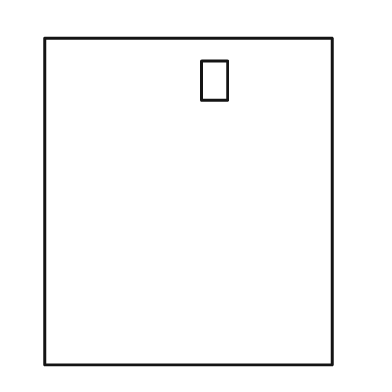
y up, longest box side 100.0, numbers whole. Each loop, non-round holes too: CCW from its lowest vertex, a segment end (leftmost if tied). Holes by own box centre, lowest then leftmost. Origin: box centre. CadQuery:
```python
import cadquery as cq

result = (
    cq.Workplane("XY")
    .moveTo(-44.0, -50.0)
    .lineTo(44.0, -50.0)
    .lineTo(44.0, 50.0)
    .lineTo(-44.0, 50.0)
    .close()
    .moveTo(4.0, 31.0)
    .lineTo(12.0, 31.0)
    .lineTo(12.0, 43.0)
    .lineTo(4.0, 43.0)
    .close()
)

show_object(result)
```